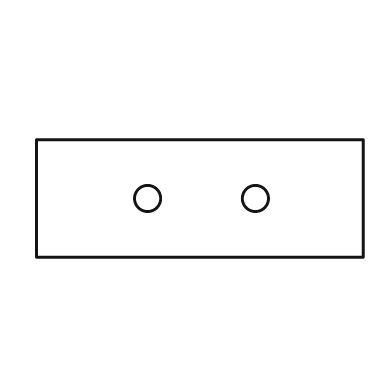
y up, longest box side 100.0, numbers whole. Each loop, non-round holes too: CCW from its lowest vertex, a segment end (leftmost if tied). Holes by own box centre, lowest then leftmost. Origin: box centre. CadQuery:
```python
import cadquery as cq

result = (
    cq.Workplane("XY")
    .moveTo(-50.0, -18.0)
    .lineTo(50.0, -18.0)
    .lineTo(50.0, 18.0)
    .lineTo(-50.0, 18.0)
    .close()
    .moveTo(-16.0, 0.0)
    .circle(4.0)
    .moveTo(17.0, 0.0)
    .circle(4.0)
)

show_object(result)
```